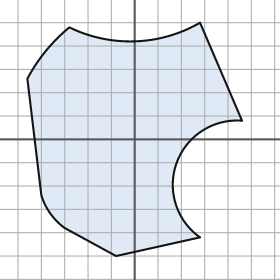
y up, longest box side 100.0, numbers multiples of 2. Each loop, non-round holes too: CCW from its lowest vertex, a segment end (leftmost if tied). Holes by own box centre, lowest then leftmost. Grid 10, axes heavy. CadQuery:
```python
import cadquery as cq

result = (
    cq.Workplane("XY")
    .moveTo(-8.0, -50.0)
    .lineTo(28.0, -42.0)
    .threePointArc((18.0, -10.0), (46.0, 8.0))
    .lineTo(28.0, 50.0)
    .threePointArc((0.0, 42.0), (-28.0, 48.0))
    .threePointArc((-38.0, 38.0), (-46.0, 26.0))
    .lineTo(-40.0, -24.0)
    .threePointArc((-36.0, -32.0), (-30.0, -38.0))
    .close()
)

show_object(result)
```